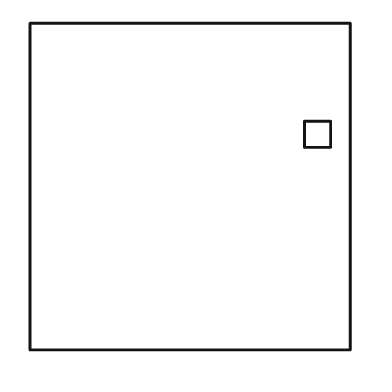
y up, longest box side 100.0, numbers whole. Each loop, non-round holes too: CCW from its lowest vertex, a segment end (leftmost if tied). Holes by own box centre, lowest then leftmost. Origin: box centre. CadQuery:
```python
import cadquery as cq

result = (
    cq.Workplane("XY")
    .moveTo(-49.0, -50.0)
    .lineTo(49.0, -50.0)
    .lineTo(49.0, 50.0)
    .lineTo(-49.0, 50.0)
    .close()
    .moveTo(35.0, 12.0)
    .lineTo(43.0, 12.0)
    .lineTo(43.0, 20.0)
    .lineTo(35.0, 20.0)
    .close()
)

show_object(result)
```